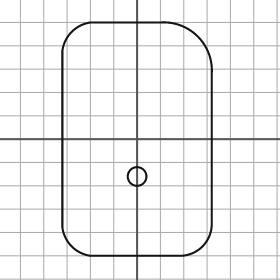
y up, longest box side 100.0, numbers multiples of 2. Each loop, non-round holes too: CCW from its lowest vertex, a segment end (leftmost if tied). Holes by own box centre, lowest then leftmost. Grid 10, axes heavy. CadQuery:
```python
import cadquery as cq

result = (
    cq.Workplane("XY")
    .moveTo(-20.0, -50.0)
    .lineTo(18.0, -50.0)
    .threePointArc((28.0, -46.0), (32.0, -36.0))
    .lineTo(32.0, 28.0)
    .threePointArc((26.0, 44.0), (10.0, 50.0))
    .lineTo(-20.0, 50.0)
    .threePointArc((-28.0, 46.0), (-32.0, 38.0))
    .lineTo(-32.0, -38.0)
    .threePointArc((-28.0, -46.0), (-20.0, -50.0))
    .close()
    .moveTo(0.0, -16.0)
    .circle(4.0)
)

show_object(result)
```